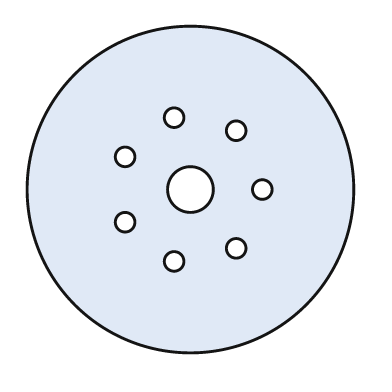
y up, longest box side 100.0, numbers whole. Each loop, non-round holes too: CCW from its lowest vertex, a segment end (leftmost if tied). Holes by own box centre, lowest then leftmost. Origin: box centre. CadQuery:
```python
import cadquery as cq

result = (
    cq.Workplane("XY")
    .moveTo(0.0, 0.0)
    .circle(50.0)
    .moveTo(-5.0, -22.0)
    .circle(3.0)
    .moveTo(14.0, -18.0)
    .circle(3.0)
    .moveTo(-20.0, -10.0)
    .circle(3.0)
    .moveTo(0.0, 0.0)
    .circle(7.0)
    .moveTo(22.0, 0.0)
    .circle(3.0)
    .moveTo(-20.0, 10.0)
    .circle(3.0)
    .moveTo(14.0, 18.0)
    .circle(3.0)
    .moveTo(-5.0, 22.0)
    .circle(3.0)
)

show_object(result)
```